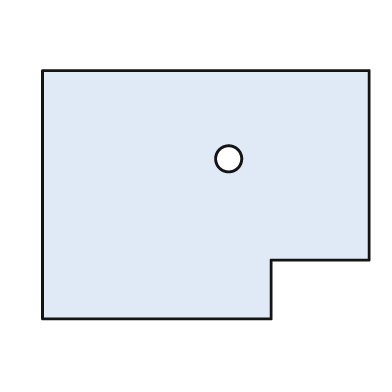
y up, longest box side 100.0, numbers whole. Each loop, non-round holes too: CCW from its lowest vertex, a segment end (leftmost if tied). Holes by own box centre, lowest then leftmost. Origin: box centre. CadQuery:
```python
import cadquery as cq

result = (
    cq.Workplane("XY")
    .moveTo(-50.0, -38.0)
    .lineTo(20.0, -38.0)
    .lineTo(20.0, -20.0)
    .lineTo(50.0, -20.0)
    .lineTo(50.0, 38.0)
    .lineTo(-50.0, 38.0)
    .close()
    .moveTo(7.0, 11.0)
    .circle(4.0)
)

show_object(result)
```